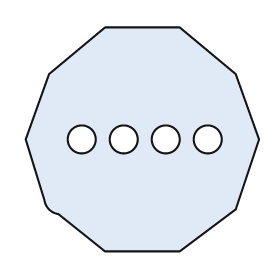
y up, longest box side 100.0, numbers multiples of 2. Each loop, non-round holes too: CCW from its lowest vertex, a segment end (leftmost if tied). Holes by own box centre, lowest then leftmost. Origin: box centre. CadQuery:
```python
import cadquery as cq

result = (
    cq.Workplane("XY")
    .moveTo(-16.0, -48.0)
    .lineTo(16.0, -48.0)
    .lineTo(40.0, -30.0)
    .lineTo(50.0, 0.0)
    .lineTo(40.0, 28.0)
    .lineTo(16.0, 48.0)
    .lineTo(-16.0, 48.0)
    .lineTo(-40.0, 28.0)
    .lineTo(-50.0, 0.0)
    .lineTo(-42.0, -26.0)
    .threePointArc((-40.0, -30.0), (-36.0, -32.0))
    .close()
    .moveTo(-26.0, 0.0)
    .circle(6.0)
    .moveTo(-8.0, 0.0)
    .circle(6.0)
    .moveTo(10.0, 0.0)
    .circle(6.0)
    .moveTo(28.0, 0.0)
    .circle(6.0)
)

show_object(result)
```